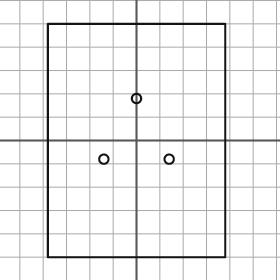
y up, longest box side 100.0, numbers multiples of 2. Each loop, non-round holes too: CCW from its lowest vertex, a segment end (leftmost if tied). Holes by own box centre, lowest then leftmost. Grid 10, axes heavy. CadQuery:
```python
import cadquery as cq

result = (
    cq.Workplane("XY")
    .moveTo(-38.0, -50.0)
    .lineTo(38.0, -50.0)
    .lineTo(38.0, 50.0)
    .lineTo(-38.0, 50.0)
    .close()
    .moveTo(-14.0, -8.0)
    .circle(2.0)
    .moveTo(14.0, -8.0)
    .circle(2.0)
    .moveTo(0.0, 18.0)
    .circle(2.0)
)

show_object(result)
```